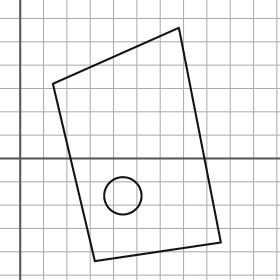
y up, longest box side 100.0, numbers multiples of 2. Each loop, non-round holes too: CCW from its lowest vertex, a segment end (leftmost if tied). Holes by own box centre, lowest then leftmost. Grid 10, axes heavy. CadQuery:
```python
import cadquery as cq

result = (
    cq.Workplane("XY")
    .moveTo(32.0, -44.0)
    .lineTo(86.0, -36.0)
    .lineTo(68.0, 56.0)
    .lineTo(14.0, 32.0)
    .close()
    .moveTo(44.0, -16.0)
    .circle(8.0)
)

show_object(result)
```